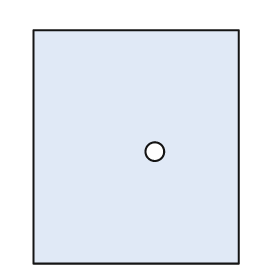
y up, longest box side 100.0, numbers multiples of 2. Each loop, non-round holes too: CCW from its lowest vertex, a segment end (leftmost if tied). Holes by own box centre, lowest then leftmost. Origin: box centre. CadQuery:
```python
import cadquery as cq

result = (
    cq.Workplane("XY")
    .moveTo(-44.0, -50.0)
    .lineTo(44.0, -50.0)
    .lineTo(44.0, 50.0)
    .lineTo(-44.0, 50.0)
    .close()
    .moveTo(8.0, -2.0)
    .circle(4.0)
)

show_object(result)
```